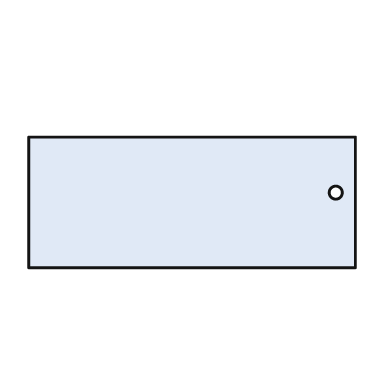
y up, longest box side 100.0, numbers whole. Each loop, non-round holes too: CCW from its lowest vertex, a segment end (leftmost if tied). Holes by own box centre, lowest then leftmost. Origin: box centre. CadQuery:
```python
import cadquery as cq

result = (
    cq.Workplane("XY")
    .moveTo(-50.0, -20.0)
    .lineTo(50.0, -20.0)
    .lineTo(50.0, 20.0)
    .lineTo(-50.0, 20.0)
    .close()
    .moveTo(44.0, 3.0)
    .circle(2.0)
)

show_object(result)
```